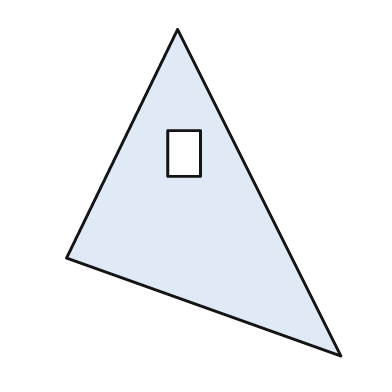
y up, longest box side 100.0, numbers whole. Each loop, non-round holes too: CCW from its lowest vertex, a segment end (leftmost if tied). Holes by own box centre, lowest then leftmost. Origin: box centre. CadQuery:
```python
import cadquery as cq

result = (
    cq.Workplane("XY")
    .moveTo(42.0, -50.0)
    .lineTo(-8.0, 50.0)
    .lineTo(-42.0, -20.0)
    .close()
    .moveTo(-11.0, 5.0)
    .lineTo(-1.0, 5.0)
    .lineTo(-1.0, 19.0)
    .lineTo(-11.0, 19.0)
    .close()
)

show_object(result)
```